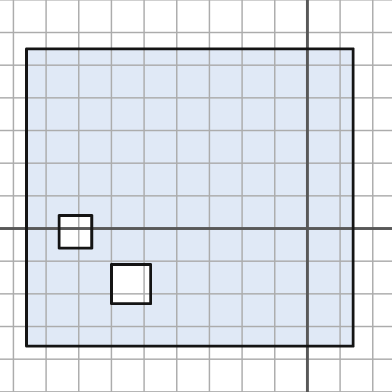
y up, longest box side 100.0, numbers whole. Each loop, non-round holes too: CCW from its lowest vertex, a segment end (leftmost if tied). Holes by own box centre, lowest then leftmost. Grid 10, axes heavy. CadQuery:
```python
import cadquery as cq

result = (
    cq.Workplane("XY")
    .moveTo(-86.0, -36.0)
    .lineTo(14.0, -36.0)
    .lineTo(14.0, 55.0)
    .lineTo(-86.0, 55.0)
    .close()
    .moveTo(-60.0, -23.0)
    .lineTo(-48.0, -23.0)
    .lineTo(-48.0, -11.0)
    .lineTo(-60.0, -11.0)
    .close()
    .moveTo(-76.0, -6.0)
    .lineTo(-66.0, -6.0)
    .lineTo(-66.0, 4.0)
    .lineTo(-76.0, 4.0)
    .close()
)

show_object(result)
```